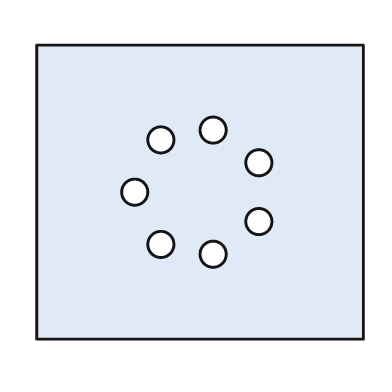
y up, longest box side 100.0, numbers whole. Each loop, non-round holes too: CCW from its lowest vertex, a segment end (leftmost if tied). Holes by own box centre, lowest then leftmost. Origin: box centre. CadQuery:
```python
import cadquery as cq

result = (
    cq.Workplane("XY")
    .moveTo(-50.0, -45.0)
    .lineTo(50.0, -45.0)
    .lineTo(50.0, 45.0)
    .lineTo(-50.0, 45.0)
    .close()
    .moveTo(4.0, -19.0)
    .circle(4.0)
    .moveTo(-12.0, -16.0)
    .circle(4.0)
    .moveTo(18.0, -9.0)
    .circle(4.0)
    .moveTo(-20.0, 0.0)
    .circle(4.0)
    .moveTo(18.0, 9.0)
    .circle(4.0)
    .moveTo(-12.0, 16.0)
    .circle(4.0)
    .moveTo(4.0, 19.0)
    .circle(4.0)
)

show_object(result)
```